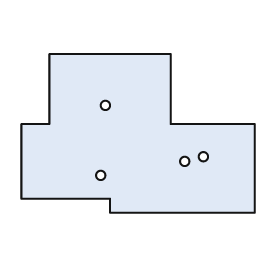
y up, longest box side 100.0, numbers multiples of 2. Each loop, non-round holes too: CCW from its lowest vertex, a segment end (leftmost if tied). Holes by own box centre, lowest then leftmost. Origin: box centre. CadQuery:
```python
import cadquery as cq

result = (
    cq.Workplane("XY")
    .moveTo(-12.0, -34.0)
    .lineTo(50.0, -34.0)
    .lineTo(50.0, 4.0)
    .lineTo(14.0, 4.0)
    .lineTo(14.0, 34.0)
    .lineTo(-38.0, 34.0)
    .lineTo(-38.0, 4.0)
    .lineTo(-50.0, 4.0)
    .lineTo(-50.0, -28.0)
    .lineTo(-12.0, -28.0)
    .close()
    .moveTo(-16.0, -18.0)
    .circle(2.0)
    .moveTo(20.0, -12.0)
    .circle(2.0)
    .moveTo(28.0, -10.0)
    .circle(2.0)
    .moveTo(-14.0, 12.0)
    .circle(2.0)
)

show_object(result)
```